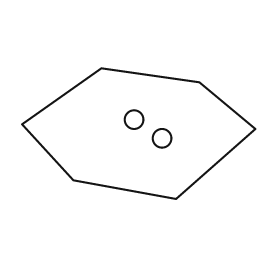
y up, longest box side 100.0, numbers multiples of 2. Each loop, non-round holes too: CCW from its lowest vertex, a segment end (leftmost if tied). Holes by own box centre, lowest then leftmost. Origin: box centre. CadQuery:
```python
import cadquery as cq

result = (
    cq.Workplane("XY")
    .moveTo(16.0, -28.0)
    .lineTo(50.0, 2.0)
    .lineTo(26.0, 22.0)
    .lineTo(-16.0, 28.0)
    .lineTo(-50.0, 4.0)
    .lineTo(-28.0, -20.0)
    .close()
    .moveTo(10.0, -2.0)
    .circle(4.0)
    .moveTo(-2.0, 6.0)
    .circle(4.0)
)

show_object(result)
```